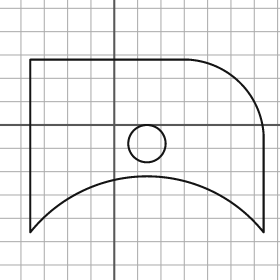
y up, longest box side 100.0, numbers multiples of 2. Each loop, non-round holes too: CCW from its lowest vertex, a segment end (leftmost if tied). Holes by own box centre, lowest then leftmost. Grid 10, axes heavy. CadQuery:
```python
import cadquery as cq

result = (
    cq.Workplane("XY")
    .moveTo(-36.0, -46.0)
    .threePointArc((14.0, -22.0), (64.0, -46.0))
    .lineTo(64.0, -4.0)
    .threePointArc((54.0, 18.0), (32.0, 28.0))
    .lineTo(-36.0, 28.0)
    .close()
    .moveTo(14.0, -8.0)
    .circle(8.0)
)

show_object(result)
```